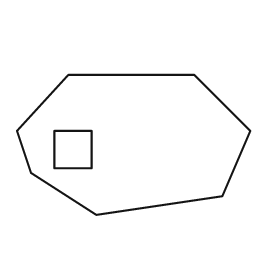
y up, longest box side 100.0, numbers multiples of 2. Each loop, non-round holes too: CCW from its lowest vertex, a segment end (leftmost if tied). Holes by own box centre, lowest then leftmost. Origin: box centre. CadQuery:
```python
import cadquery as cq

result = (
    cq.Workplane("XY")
    .moveTo(-16.0, -30.0)
    .lineTo(38.0, -22.0)
    .lineTo(50.0, 6.0)
    .lineTo(26.0, 30.0)
    .lineTo(-28.0, 30.0)
    .lineTo(-50.0, 6.0)
    .lineTo(-44.0, -12.0)
    .close()
    .moveTo(-34.0, -10.0)
    .lineTo(-18.0, -10.0)
    .lineTo(-18.0, 6.0)
    .lineTo(-34.0, 6.0)
    .close()
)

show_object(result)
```